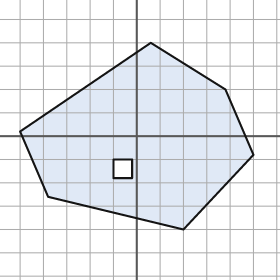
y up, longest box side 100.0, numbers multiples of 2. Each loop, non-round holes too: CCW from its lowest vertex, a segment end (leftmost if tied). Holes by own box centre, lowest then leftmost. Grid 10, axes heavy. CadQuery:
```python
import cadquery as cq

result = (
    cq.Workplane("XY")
    .moveTo(20.0, -40.0)
    .lineTo(50.0, -8.0)
    .lineTo(38.0, 20.0)
    .lineTo(6.0, 40.0)
    .lineTo(-50.0, 2.0)
    .lineTo(-38.0, -26.0)
    .close()
    .moveTo(-10.0, -18.0)
    .lineTo(-2.0, -18.0)
    .lineTo(-2.0, -10.0)
    .lineTo(-10.0, -10.0)
    .close()
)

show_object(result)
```